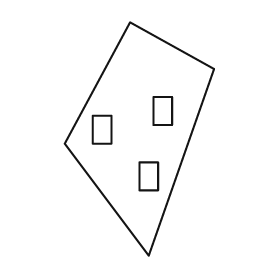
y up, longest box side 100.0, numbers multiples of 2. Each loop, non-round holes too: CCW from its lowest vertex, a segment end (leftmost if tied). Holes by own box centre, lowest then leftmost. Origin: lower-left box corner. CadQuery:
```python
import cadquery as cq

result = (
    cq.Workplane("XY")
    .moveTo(36.0, 0.0)
    .lineTo(64.0, 80.0)
    .lineTo(28.0, 100.0)
    .lineTo(0.0, 48.0)
    .close()
    .moveTo(32.0, 28.0)
    .lineTo(40.0, 28.0)
    .lineTo(40.0, 40.0)
    .lineTo(32.0, 40.0)
    .close()
    .moveTo(12.0, 48.0)
    .lineTo(20.0, 48.0)
    .lineTo(20.0, 60.0)
    .lineTo(12.0, 60.0)
    .close()
    .moveTo(38.0, 56.0)
    .lineTo(46.0, 56.0)
    .lineTo(46.0, 68.0)
    .lineTo(38.0, 68.0)
    .close()
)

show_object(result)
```